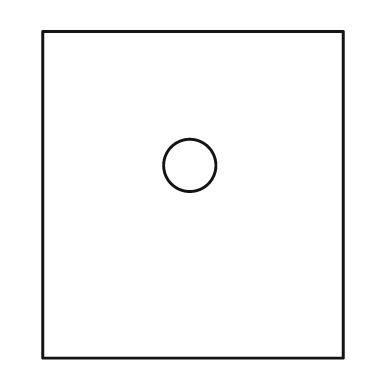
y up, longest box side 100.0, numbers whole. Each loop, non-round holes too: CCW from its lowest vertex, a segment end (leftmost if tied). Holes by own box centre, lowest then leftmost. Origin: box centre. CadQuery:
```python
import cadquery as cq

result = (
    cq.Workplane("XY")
    .moveTo(-46.0, -50.0)
    .lineTo(46.0, -50.0)
    .lineTo(46.0, 50.0)
    .lineTo(-46.0, 50.0)
    .close()
    .moveTo(-1.0, 9.0)
    .circle(8.0)
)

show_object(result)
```